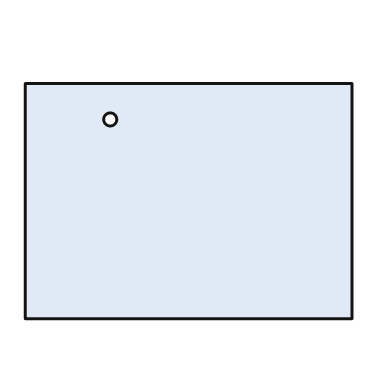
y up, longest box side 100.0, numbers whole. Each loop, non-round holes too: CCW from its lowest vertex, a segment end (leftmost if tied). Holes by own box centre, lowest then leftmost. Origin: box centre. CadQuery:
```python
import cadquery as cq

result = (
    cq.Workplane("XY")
    .moveTo(-50.0, -36.0)
    .lineTo(50.0, -36.0)
    .lineTo(50.0, 36.0)
    .lineTo(-50.0, 36.0)
    .close()
    .moveTo(-24.0, 25.0)
    .circle(2.0)
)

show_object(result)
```